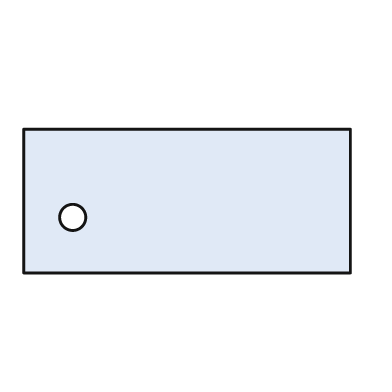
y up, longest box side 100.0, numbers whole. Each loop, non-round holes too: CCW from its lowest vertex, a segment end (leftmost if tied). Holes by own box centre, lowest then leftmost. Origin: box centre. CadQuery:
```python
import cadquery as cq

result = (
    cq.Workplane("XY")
    .moveTo(-50.0, -22.0)
    .lineTo(50.0, -22.0)
    .lineTo(50.0, 22.0)
    .lineTo(-50.0, 22.0)
    .close()
    .moveTo(-35.0, -5.0)
    .circle(4.0)
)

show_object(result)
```